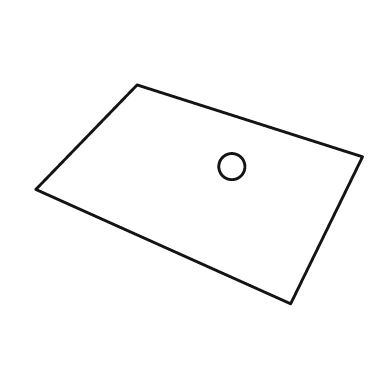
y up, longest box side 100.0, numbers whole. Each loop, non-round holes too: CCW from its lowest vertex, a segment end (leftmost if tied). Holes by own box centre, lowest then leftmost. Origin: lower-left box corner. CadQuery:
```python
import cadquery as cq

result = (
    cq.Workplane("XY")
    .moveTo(78.0, 0.0)
    .lineTo(100.0, 45.0)
    .lineTo(31.0, 67.0)
    .lineTo(0.0, 35.0)
    .close()
    .moveTo(60.0, 42.0)
    .circle(4.0)
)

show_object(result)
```